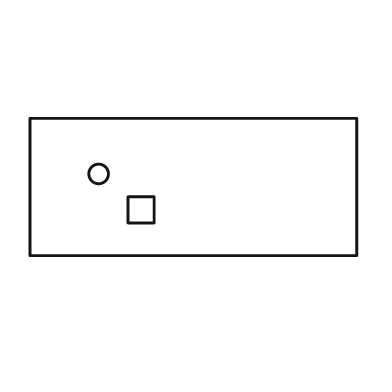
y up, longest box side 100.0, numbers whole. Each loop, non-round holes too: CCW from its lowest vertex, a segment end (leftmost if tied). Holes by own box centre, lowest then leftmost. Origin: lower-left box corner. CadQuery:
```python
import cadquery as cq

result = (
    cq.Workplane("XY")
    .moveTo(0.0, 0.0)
    .lineTo(100.0, 0.0)
    .lineTo(100.0, 42.0)
    .lineTo(0.0, 42.0)
    .close()
    .moveTo(30.0, 10.0)
    .lineTo(38.0, 10.0)
    .lineTo(38.0, 18.0)
    .lineTo(30.0, 18.0)
    .close()
    .moveTo(21.0, 25.0)
    .circle(3.0)
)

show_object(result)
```